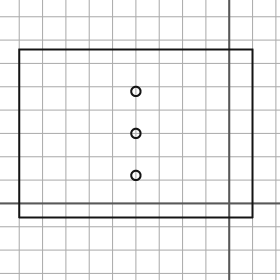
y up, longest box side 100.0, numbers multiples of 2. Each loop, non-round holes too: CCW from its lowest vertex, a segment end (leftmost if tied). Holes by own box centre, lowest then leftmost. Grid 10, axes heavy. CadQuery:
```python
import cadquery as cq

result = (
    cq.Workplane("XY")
    .moveTo(-90.0, -6.0)
    .lineTo(10.0, -6.0)
    .lineTo(10.0, 66.0)
    .lineTo(-90.0, 66.0)
    .close()
    .moveTo(-40.0, 12.0)
    .circle(2.0)
    .moveTo(-40.0, 30.0)
    .circle(2.0)
    .moveTo(-40.0, 48.0)
    .circle(2.0)
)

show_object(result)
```